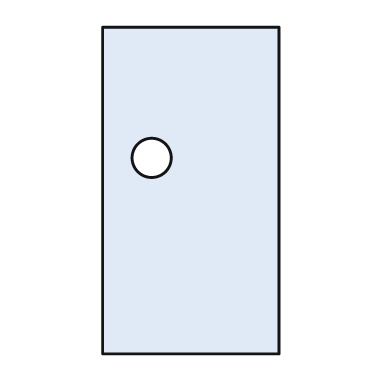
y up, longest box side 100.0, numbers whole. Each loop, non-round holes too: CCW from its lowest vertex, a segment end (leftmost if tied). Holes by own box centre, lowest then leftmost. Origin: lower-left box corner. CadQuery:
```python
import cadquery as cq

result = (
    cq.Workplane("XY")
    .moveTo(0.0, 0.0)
    .lineTo(54.0, 0.0)
    .lineTo(54.0, 100.0)
    .lineTo(0.0, 100.0)
    .close()
    .moveTo(15.0, 60.0)
    .circle(6.0)
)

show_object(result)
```